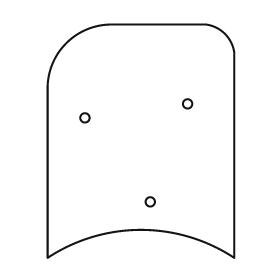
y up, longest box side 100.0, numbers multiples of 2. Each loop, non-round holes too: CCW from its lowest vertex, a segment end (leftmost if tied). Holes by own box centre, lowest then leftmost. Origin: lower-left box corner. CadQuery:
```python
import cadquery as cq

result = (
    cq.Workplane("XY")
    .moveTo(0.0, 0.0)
    .threePointArc((40.0, 12.0), (80.0, 0.0))
    .lineTo(80.0, 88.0)
    .threePointArc((76.0, 96.0), (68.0, 100.0))
    .lineTo(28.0, 100.0)
    .threePointArc((8.0, 92.0), (0.0, 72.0))
    .close()
    .moveTo(44.0, 24.0)
    .circle(2.0)
    .moveTo(16.0, 60.0)
    .circle(2.0)
    .moveTo(60.0, 66.0)
    .circle(2.0)
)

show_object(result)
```